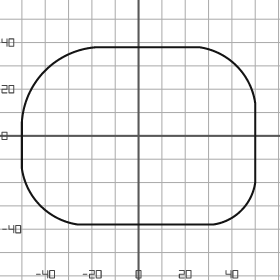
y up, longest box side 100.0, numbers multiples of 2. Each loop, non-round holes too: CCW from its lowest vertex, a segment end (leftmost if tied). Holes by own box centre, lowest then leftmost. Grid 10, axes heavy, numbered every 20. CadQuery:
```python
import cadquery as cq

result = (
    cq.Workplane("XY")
    .moveTo(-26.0, -38.0)
    .lineTo(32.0, -38.0)
    .threePointArc((44.0, -32.0), (50.0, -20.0))
    .lineTo(50.0, 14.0)
    .threePointArc((42.0, 30.0), (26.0, 38.0))
    .lineTo(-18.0, 38.0)
    .threePointArc((-40.0, 28.0), (-50.0, 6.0))
    .lineTo(-50.0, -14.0)
    .threePointArc((-42.0, -30.0), (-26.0, -38.0))
    .close()
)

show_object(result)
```